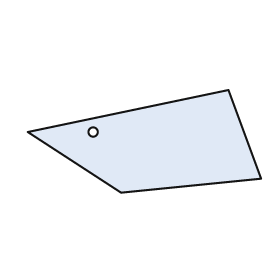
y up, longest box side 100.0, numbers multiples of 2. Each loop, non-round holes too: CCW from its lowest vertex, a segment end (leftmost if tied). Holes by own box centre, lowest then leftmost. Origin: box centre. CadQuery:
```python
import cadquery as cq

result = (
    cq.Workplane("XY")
    .moveTo(-10.0, -22.0)
    .lineTo(50.0, -16.0)
    .lineTo(36.0, 22.0)
    .lineTo(-50.0, 4.0)
    .close()
    .moveTo(-22.0, 4.0)
    .circle(2.0)
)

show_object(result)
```